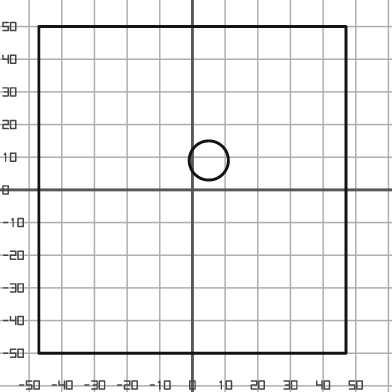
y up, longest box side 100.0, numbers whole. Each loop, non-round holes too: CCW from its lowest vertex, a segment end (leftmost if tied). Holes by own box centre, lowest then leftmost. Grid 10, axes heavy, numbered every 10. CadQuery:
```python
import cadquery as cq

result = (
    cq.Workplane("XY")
    .moveTo(-47.0, -50.0)
    .lineTo(47.0, -50.0)
    .lineTo(47.0, 50.0)
    .lineTo(-47.0, 50.0)
    .close()
    .moveTo(5.0, 9.0)
    .circle(6.0)
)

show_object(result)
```